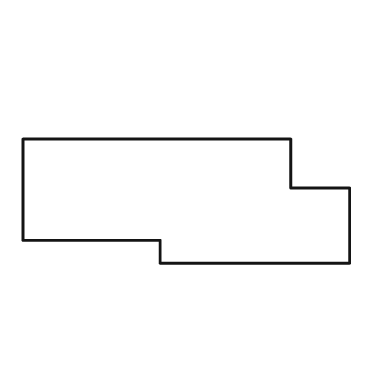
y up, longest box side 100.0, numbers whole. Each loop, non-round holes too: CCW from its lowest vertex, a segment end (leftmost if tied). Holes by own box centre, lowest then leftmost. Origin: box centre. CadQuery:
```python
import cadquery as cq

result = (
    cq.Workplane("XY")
    .moveTo(-8.0, -19.0)
    .lineTo(50.0, -19.0)
    .lineTo(50.0, 4.0)
    .lineTo(32.0, 4.0)
    .lineTo(32.0, 19.0)
    .lineTo(-50.0, 19.0)
    .lineTo(-50.0, -12.0)
    .lineTo(-8.0, -12.0)
    .close()
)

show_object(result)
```